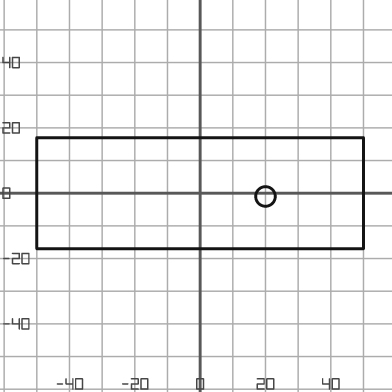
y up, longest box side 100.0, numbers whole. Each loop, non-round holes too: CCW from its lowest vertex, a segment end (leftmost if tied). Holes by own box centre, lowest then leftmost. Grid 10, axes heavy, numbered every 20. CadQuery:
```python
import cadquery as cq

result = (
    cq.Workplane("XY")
    .moveTo(-50.0, -17.0)
    .lineTo(50.0, -17.0)
    .lineTo(50.0, 17.0)
    .lineTo(-50.0, 17.0)
    .close()
    .moveTo(20.0, -1.0)
    .circle(3.0)
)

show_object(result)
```